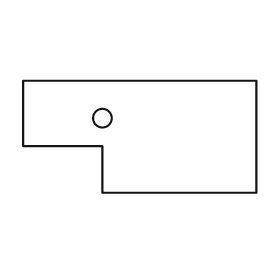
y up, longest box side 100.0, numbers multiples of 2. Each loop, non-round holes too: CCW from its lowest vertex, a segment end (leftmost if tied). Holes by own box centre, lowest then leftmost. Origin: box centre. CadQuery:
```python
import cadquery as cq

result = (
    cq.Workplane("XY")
    .moveTo(-16.0, -24.0)
    .lineTo(50.0, -24.0)
    .lineTo(50.0, 24.0)
    .lineTo(-50.0, 24.0)
    .lineTo(-50.0, -4.0)
    .lineTo(-16.0, -4.0)
    .close()
    .moveTo(-16.0, 8.0)
    .circle(4.0)
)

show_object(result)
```